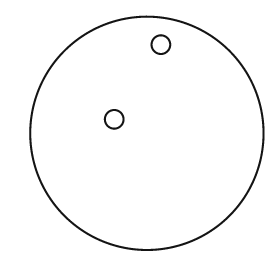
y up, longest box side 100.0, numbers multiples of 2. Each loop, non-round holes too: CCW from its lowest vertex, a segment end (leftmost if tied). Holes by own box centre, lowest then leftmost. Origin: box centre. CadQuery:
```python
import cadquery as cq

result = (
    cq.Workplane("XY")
    .moveTo(0.0, 0.0)
    .circle(50.0)
    .moveTo(-14.0, 6.0)
    .circle(4.0)
    .moveTo(6.0, 38.0)
    .circle(4.0)
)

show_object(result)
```